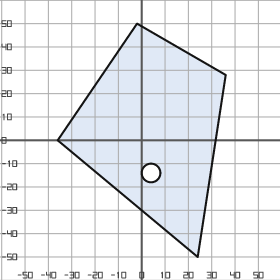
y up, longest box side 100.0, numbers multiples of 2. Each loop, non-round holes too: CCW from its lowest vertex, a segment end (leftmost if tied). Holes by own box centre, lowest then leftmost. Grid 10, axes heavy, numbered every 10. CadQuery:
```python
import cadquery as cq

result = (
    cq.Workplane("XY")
    .moveTo(24.0, -50.0)
    .lineTo(36.0, 28.0)
    .lineTo(-2.0, 50.0)
    .lineTo(-36.0, 0.0)
    .close()
    .moveTo(4.0, -14.0)
    .circle(4.0)
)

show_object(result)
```